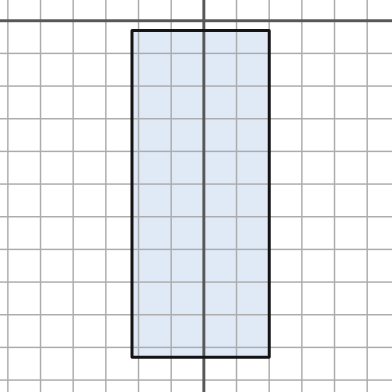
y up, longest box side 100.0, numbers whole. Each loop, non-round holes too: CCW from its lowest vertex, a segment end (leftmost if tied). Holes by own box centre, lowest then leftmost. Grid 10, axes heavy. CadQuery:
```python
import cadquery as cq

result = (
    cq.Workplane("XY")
    .moveTo(-22.0, -103.0)
    .lineTo(20.0, -103.0)
    .lineTo(20.0, -3.0)
    .lineTo(-22.0, -3.0)
    .close()
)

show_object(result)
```